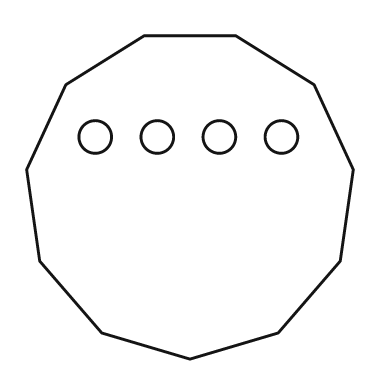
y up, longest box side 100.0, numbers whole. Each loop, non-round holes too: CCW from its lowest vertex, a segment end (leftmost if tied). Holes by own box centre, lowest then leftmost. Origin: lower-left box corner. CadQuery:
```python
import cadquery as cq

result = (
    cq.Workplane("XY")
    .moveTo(50.0, 0.0)
    .lineTo(77.0, 8.0)
    .lineTo(96.0, 30.0)
    .lineTo(100.0, 58.0)
    .lineTo(88.0, 84.0)
    .lineTo(64.0, 99.0)
    .lineTo(36.0, 99.0)
    .lineTo(12.0, 84.0)
    .lineTo(0.0, 58.0)
    .lineTo(4.0, 30.0)
    .lineTo(23.0, 8.0)
    .close()
    .moveTo(21.0, 68.0)
    .circle(5.0)
    .moveTo(40.0, 68.0)
    .circle(5.0)
    .moveTo(59.0, 68.0)
    .circle(5.0)
    .moveTo(78.0, 68.0)
    .circle(5.0)
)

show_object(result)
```